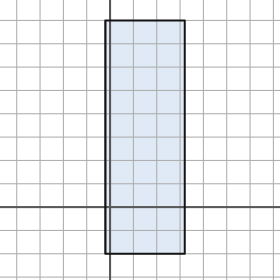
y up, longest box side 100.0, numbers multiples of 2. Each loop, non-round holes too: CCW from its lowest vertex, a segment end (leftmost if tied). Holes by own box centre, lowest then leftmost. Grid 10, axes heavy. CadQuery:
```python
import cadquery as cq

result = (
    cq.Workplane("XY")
    .moveTo(-2.0, -20.0)
    .lineTo(32.0, -20.0)
    .lineTo(32.0, 80.0)
    .lineTo(-2.0, 80.0)
    .close()
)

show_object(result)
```